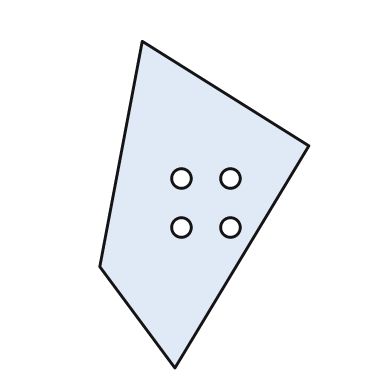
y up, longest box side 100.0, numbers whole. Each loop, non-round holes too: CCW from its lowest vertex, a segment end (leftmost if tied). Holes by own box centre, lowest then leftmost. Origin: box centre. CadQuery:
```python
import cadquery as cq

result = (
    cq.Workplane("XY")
    .moveTo(-9.0, -50.0)
    .lineTo(32.0, 18.0)
    .lineTo(-19.0, 50.0)
    .lineTo(-32.0, -19.0)
    .close()
    .moveTo(-7.0, -7.0)
    .circle(3.0)
    .moveTo(8.0, -7.0)
    .circle(3.0)
    .moveTo(-7.0, 8.0)
    .circle(3.0)
    .moveTo(8.0, 8.0)
    .circle(3.0)
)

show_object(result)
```